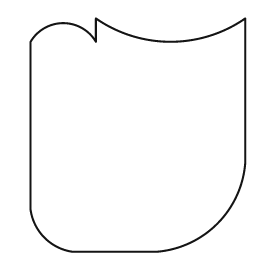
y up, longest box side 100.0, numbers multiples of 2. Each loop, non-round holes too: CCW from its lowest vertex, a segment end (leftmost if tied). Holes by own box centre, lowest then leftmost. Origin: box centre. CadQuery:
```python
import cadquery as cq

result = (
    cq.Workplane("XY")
    .moveTo(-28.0, -50.0)
    .lineTo(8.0, -50.0)
    .threePointArc((34.0, -38.0), (46.0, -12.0))
    .lineTo(46.0, 50.0)
    .threePointArc((14.0, 40.0), (-18.0, 50.0))
    .lineTo(-18.0, 40.0)
    .threePointArc((-32.0, 48.0), (-46.0, 40.0))
    .lineTo(-46.0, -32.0)
    .threePointArc((-40.0, -44.0), (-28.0, -50.0))
    .close()
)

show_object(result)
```